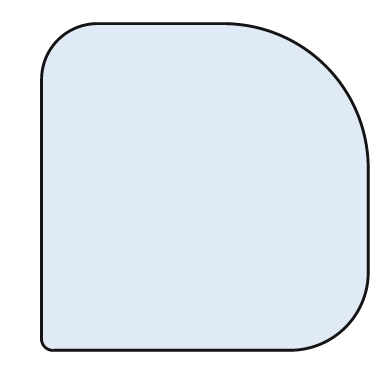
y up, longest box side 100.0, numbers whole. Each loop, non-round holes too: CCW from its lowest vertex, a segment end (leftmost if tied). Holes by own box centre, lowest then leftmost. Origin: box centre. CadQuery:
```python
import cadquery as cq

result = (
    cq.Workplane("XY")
    .moveTo(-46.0, -50.0)
    .lineTo(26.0, -50.0)
    .threePointArc((43.0, -43.0), (50.0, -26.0))
    .lineTo(50.0, 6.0)
    .threePointArc((37.0, 37.0), (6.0, 50.0))
    .lineTo(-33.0, 50.0)
    .threePointArc((-45.0, 45.0), (-50.0, 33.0))
    .lineTo(-50.0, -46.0)
    .threePointArc((-49.0, -49.0), (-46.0, -50.0))
    .close()
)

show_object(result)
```